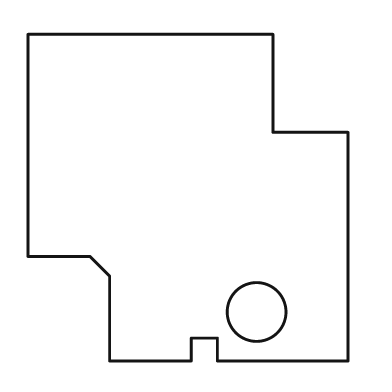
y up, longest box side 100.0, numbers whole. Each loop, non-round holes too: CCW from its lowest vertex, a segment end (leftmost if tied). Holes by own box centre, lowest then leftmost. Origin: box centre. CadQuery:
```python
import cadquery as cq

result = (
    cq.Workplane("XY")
    .moveTo(-24.0, -50.0)
    .lineTo(1.0, -50.0)
    .lineTo(1.0, -43.0)
    .lineTo(9.0, -43.0)
    .lineTo(9.0, -50.0)
    .lineTo(49.0, -50.0)
    .lineTo(49.0, 20.0)
    .lineTo(26.0, 20.0)
    .lineTo(26.0, 50.0)
    .lineTo(-49.0, 50.0)
    .lineTo(-49.0, -18.0)
    .lineTo(-30.0, -18.0)
    .lineTo(-24.0, -24.0)
    .close()
    .moveTo(21.0, -35.0)
    .circle(9.0)
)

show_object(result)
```